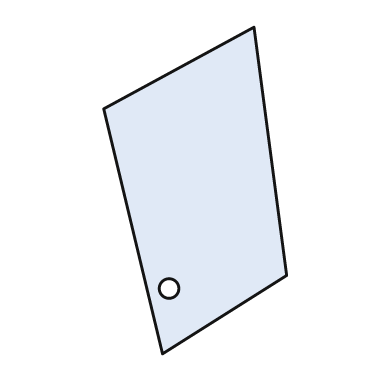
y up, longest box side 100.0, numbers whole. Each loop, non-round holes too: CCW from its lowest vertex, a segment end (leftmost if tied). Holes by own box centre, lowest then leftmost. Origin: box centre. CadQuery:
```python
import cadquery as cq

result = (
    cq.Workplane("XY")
    .moveTo(-10.0, -50.0)
    .lineTo(28.0, -26.0)
    .lineTo(18.0, 50.0)
    .lineTo(-28.0, 25.0)
    .close()
    .moveTo(-8.0, -30.0)
    .circle(3.0)
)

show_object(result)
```